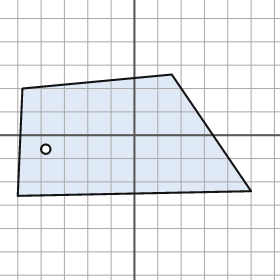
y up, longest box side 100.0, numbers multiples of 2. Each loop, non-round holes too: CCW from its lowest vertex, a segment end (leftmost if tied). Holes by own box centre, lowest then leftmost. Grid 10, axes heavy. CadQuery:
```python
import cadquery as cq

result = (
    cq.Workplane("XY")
    .moveTo(-50.0, -26.0)
    .lineTo(50.0, -24.0)
    .lineTo(16.0, 26.0)
    .lineTo(-48.0, 20.0)
    .close()
    .moveTo(-38.0, -6.0)
    .circle(2.0)
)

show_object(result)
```